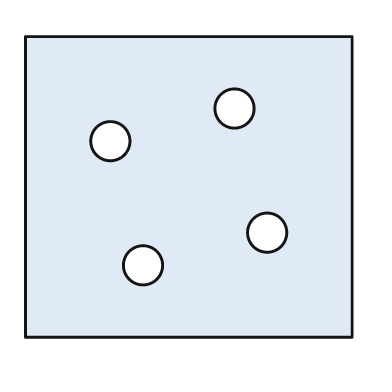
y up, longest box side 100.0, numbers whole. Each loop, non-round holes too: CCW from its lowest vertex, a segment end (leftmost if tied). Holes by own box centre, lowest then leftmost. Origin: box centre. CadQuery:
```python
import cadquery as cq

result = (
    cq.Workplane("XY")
    .moveTo(-50.0, -46.0)
    .lineTo(50.0, -46.0)
    .lineTo(50.0, 46.0)
    .lineTo(-50.0, 46.0)
    .close()
    .moveTo(-14.0, -24.0)
    .circle(6.0)
    .moveTo(24.0, -14.0)
    .circle(6.0)
    .moveTo(-24.0, 14.0)
    .circle(6.0)
    .moveTo(14.0, 24.0)
    .circle(6.0)
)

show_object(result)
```